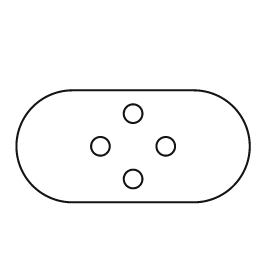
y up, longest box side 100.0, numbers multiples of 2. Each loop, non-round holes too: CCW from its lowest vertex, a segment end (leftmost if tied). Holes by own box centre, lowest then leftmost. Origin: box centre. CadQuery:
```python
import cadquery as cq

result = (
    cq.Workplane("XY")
    .moveTo(-26.0, -24.0)
    .lineTo(26.0, -24.0)
    .threePointArc((50.0, 0.0), (26.0, 24.0))
    .lineTo(-26.0, 24.0)
    .threePointArc((-50.0, 0.0), (-26.0, -24.0))
    .close()
    .moveTo(0.0, -14.0)
    .circle(4.0)
    .moveTo(-14.0, 0.0)
    .circle(4.0)
    .moveTo(14.0, 0.0)
    .circle(4.0)
    .moveTo(0.0, 14.0)
    .circle(4.0)
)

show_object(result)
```